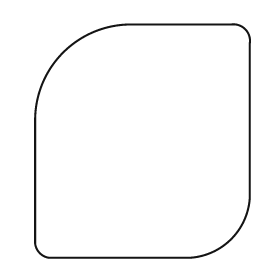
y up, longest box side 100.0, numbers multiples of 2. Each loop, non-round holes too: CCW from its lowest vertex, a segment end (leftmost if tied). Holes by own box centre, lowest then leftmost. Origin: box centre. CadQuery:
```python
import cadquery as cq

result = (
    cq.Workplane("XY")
    .moveTo(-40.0, -50.0)
    .lineTo(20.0, -50.0)
    .threePointArc((38.0, -42.0), (46.0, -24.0))
    .lineTo(46.0, 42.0)
    .threePointArc((44.0, 48.0), (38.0, 50.0))
    .lineTo(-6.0, 50.0)
    .threePointArc((-34.0, 38.0), (-46.0, 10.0))
    .lineTo(-46.0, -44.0)
    .threePointArc((-44.0, -48.0), (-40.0, -50.0))
    .close()
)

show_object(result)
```